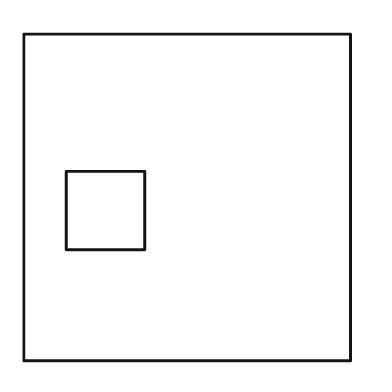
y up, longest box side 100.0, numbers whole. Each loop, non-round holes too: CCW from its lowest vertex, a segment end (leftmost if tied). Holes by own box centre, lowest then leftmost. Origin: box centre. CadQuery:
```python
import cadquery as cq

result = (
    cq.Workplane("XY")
    .moveTo(-50.0, -50.0)
    .lineTo(50.0, -50.0)
    .lineTo(50.0, 50.0)
    .lineTo(-50.0, 50.0)
    .close()
    .moveTo(-37.0, -16.0)
    .lineTo(-13.0, -16.0)
    .lineTo(-13.0, 8.0)
    .lineTo(-37.0, 8.0)
    .close()
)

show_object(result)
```